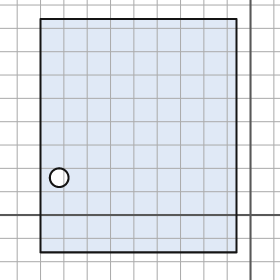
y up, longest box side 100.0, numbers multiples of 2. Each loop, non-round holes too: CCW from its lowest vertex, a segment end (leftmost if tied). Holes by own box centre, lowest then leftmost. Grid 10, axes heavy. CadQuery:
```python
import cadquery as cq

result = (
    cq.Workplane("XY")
    .moveTo(-90.0, -16.0)
    .lineTo(-6.0, -16.0)
    .lineTo(-6.0, 84.0)
    .lineTo(-90.0, 84.0)
    .close()
    .moveTo(-82.0, 16.0)
    .circle(4.0)
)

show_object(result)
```